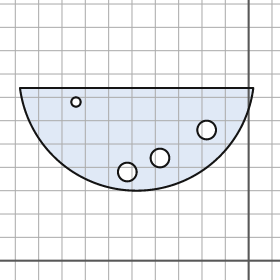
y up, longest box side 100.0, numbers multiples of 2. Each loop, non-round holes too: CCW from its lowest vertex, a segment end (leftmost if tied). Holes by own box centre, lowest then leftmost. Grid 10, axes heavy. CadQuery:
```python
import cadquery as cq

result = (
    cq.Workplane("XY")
    .moveTo(-98.0, 74.0)
    .threePointArc((-48.0, 30.0), (2.0, 74.0))
    .close()
    .moveTo(-52.0, 38.0)
    .circle(4.0)
    .moveTo(-38.0, 44.0)
    .circle(4.0)
    .moveTo(-18.0, 56.0)
    .circle(4.0)
    .moveTo(-74.0, 68.0)
    .circle(2.0)
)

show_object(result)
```